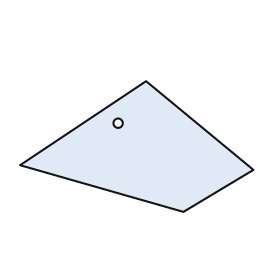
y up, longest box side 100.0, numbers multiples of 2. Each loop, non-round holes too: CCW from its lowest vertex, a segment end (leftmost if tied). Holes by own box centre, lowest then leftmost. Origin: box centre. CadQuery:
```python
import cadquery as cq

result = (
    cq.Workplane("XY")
    .moveTo(20.0, -28.0)
    .lineTo(50.0, -10.0)
    .lineTo(4.0, 28.0)
    .lineTo(-50.0, -8.0)
    .close()
    .moveTo(-8.0, 10.0)
    .circle(2.0)
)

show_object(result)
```